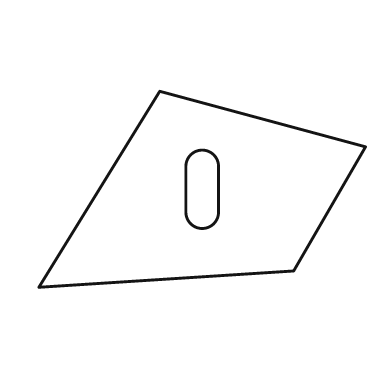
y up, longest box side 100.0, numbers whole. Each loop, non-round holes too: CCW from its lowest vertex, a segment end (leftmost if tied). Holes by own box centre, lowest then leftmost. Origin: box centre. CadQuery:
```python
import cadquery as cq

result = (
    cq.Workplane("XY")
    .moveTo(-50.0, -30.0)
    .lineTo(28.0, -25.0)
    .lineTo(50.0, 13.0)
    .lineTo(-13.0, 30.0)
    .close()
    .moveTo(-5.0, -7.0)
    .threePointArc((0.0, -12.0), (5.0, -7.0))
    .lineTo(5.0, 7.0)
    .threePointArc((0.0, 12.0), (-5.0, 7.0))
    .close()
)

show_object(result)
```